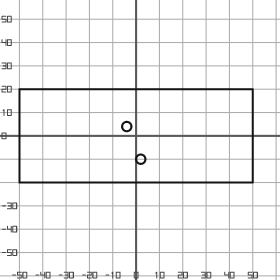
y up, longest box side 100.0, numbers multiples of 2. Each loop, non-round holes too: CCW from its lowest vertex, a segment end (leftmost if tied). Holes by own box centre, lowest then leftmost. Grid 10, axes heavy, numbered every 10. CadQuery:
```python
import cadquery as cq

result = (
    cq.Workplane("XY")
    .moveTo(-50.0, -20.0)
    .lineTo(50.0, -20.0)
    .lineTo(50.0, 20.0)
    .lineTo(-50.0, 20.0)
    .close()
    .moveTo(2.0, -10.0)
    .circle(2.0)
    .moveTo(-4.0, 4.0)
    .circle(2.0)
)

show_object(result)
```